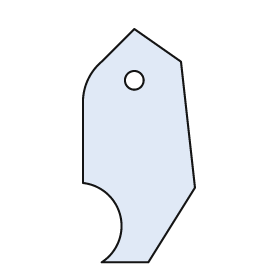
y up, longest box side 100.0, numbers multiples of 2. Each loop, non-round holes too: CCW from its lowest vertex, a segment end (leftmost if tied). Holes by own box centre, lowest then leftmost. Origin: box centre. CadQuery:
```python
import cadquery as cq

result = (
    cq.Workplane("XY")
    .moveTo(-16.0, -50.0)
    .lineTo(4.0, -50.0)
    .lineTo(24.0, -18.0)
    .lineTo(18.0, 36.0)
    .lineTo(-2.0, 50.0)
    .lineTo(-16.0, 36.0)
    .threePointArc((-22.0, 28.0), (-24.0, 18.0))
    .lineTo(-24.0, -16.0)
    .threePointArc((-8.0, -30.0), (-16.0, -50.0))
    .close()
    .moveTo(-2.0, 28.0)
    .circle(4.0)
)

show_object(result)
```